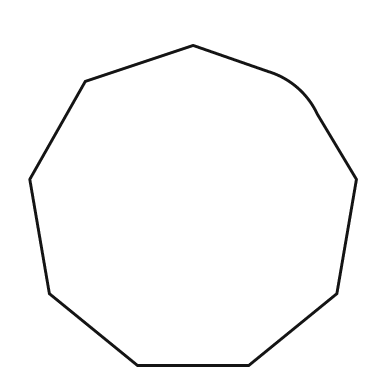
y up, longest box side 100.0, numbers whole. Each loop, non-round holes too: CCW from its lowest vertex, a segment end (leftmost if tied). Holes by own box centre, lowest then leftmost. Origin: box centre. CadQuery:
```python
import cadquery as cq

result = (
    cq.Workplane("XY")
    .moveTo(-17.0, -49.0)
    .lineTo(17.0, -49.0)
    .lineTo(44.0, -27.0)
    .lineTo(50.0, 8.0)
    .lineTo(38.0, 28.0)
    .threePointArc((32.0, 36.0), (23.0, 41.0))
    .lineTo(0.0, 49.0)
    .lineTo(-33.0, 38.0)
    .lineTo(-50.0, 8.0)
    .lineTo(-44.0, -27.0)
    .close()
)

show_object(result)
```